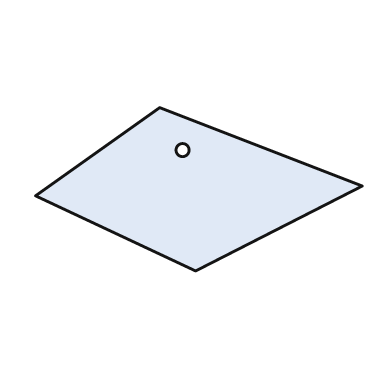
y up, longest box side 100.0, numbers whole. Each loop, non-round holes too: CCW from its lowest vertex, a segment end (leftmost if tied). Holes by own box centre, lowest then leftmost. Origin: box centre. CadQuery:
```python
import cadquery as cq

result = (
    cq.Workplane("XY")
    .moveTo(-1.0, -25.0)
    .lineTo(50.0, 1.0)
    .lineTo(-12.0, 25.0)
    .lineTo(-50.0, -2.0)
    .close()
    .moveTo(-5.0, 12.0)
    .circle(2.0)
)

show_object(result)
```